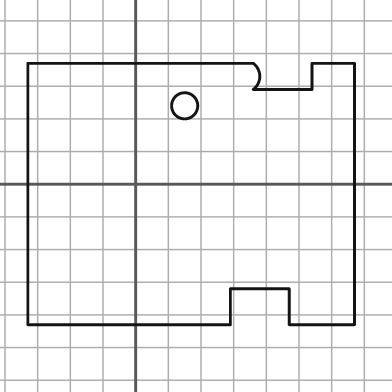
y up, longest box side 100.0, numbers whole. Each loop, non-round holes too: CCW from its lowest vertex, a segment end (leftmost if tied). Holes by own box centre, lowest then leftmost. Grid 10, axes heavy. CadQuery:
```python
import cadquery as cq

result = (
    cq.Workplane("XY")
    .moveTo(-33.0, -43.0)
    .lineTo(29.0, -43.0)
    .lineTo(29.0, -32.0)
    .lineTo(47.0, -32.0)
    .lineTo(47.0, -43.0)
    .lineTo(67.0, -43.0)
    .lineTo(67.0, 37.0)
    .lineTo(54.0, 37.0)
    .lineTo(54.0, 29.0)
    .lineTo(36.0, 29.0)
    .threePointArc((38.0, 33.0), (36.0, 37.0))
    .lineTo(-33.0, 37.0)
    .close()
    .moveTo(15.0, 24.0)
    .circle(4.0)
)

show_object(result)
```